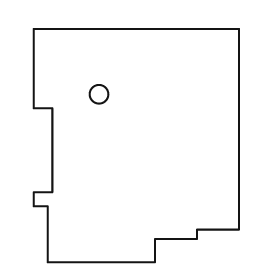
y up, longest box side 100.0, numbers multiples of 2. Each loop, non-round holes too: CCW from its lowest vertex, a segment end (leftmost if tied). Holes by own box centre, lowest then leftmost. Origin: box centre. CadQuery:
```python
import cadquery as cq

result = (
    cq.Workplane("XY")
    .moveTo(-38.0, -50.0)
    .lineTo(8.0, -50.0)
    .lineTo(8.0, -40.0)
    .lineTo(26.0, -40.0)
    .lineTo(26.0, -36.0)
    .lineTo(44.0, -36.0)
    .lineTo(44.0, 50.0)
    .lineTo(-44.0, 50.0)
    .lineTo(-44.0, 16.0)
    .lineTo(-36.0, 16.0)
    .lineTo(-36.0, -20.0)
    .lineTo(-44.0, -20.0)
    .lineTo(-44.0, -26.0)
    .lineTo(-38.0, -26.0)
    .close()
    .moveTo(-16.0, 22.0)
    .circle(4.0)
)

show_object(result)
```